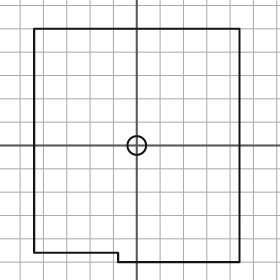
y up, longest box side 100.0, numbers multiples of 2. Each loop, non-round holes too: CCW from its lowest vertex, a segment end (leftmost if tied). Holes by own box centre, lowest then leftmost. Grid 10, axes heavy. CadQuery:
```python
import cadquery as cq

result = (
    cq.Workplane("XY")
    .moveTo(-8.0, -50.0)
    .lineTo(44.0, -50.0)
    .lineTo(44.0, 50.0)
    .lineTo(-44.0, 50.0)
    .lineTo(-44.0, -46.0)
    .lineTo(-8.0, -46.0)
    .close()
    .moveTo(0.0, 0.0)
    .circle(4.0)
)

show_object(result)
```